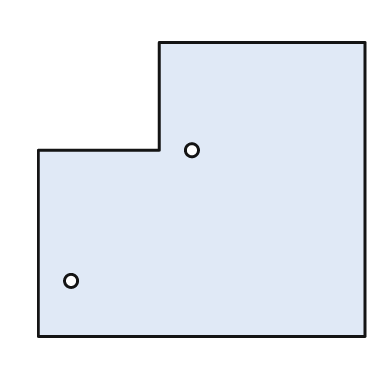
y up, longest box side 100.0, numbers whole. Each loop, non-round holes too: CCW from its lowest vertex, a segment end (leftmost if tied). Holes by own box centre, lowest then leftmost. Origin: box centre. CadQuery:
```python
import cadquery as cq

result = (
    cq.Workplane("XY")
    .moveTo(-50.0, -45.0)
    .lineTo(50.0, -45.0)
    .lineTo(50.0, 45.0)
    .lineTo(-13.0, 45.0)
    .lineTo(-13.0, 12.0)
    .lineTo(-50.0, 12.0)
    .close()
    .moveTo(-40.0, -28.0)
    .circle(2.0)
    .moveTo(-3.0, 12.0)
    .circle(2.0)
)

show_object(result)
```